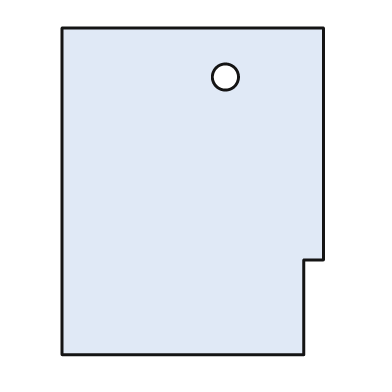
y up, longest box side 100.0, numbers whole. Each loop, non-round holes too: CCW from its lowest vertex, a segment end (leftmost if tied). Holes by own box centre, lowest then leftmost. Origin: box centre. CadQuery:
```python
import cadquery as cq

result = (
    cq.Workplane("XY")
    .moveTo(-40.0, -50.0)
    .lineTo(34.0, -50.0)
    .lineTo(34.0, -21.0)
    .lineTo(40.0, -21.0)
    .lineTo(40.0, 50.0)
    .lineTo(-40.0, 50.0)
    .close()
    .moveTo(10.0, 35.0)
    .circle(4.0)
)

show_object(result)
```